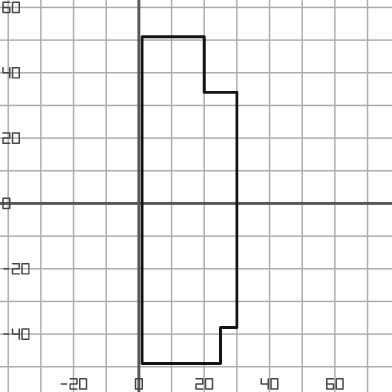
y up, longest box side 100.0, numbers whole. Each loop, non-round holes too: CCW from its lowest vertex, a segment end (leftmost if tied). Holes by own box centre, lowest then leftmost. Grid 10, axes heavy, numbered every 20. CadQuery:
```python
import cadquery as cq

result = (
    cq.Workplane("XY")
    .moveTo(1.0, -49.0)
    .lineTo(25.0, -49.0)
    .lineTo(25.0, -38.0)
    .lineTo(30.0, -38.0)
    .lineTo(30.0, 34.0)
    .lineTo(20.0, 34.0)
    .lineTo(20.0, 51.0)
    .lineTo(1.0, 51.0)
    .close()
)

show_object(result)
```